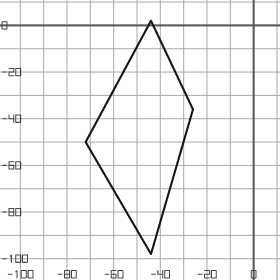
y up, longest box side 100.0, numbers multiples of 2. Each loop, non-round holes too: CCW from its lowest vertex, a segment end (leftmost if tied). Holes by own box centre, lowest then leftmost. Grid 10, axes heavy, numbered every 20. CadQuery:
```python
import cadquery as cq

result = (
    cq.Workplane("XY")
    .moveTo(-44.0, -98.0)
    .lineTo(-26.0, -36.0)
    .lineTo(-44.0, 2.0)
    .lineTo(-72.0, -50.0)
    .close()
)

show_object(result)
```